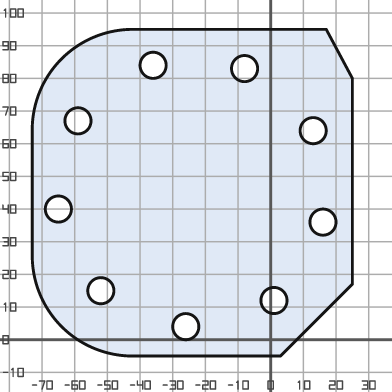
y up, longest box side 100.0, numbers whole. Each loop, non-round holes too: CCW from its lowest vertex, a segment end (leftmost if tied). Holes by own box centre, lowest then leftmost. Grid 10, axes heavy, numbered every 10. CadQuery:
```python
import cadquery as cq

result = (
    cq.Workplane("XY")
    .moveTo(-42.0, -5.0)
    .lineTo(3.0, -5.0)
    .lineTo(25.0, 17.0)
    .lineTo(25.0, 80.0)
    .lineTo(17.0, 95.0)
    .lineTo(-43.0, 95.0)
    .threePointArc((-64.0, 86.0), (-73.0, 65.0))
    .lineTo(-73.0, 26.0)
    .threePointArc((-64.0, 4.0), (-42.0, -5.0))
    .close()
    .moveTo(-26.0, 4.0)
    .circle(4.0)
    .moveTo(1.0, 12.0)
    .circle(4.0)
    .moveTo(-52.0, 15.0)
    .circle(4.0)
    .moveTo(16.0, 36.0)
    .circle(4.0)
    .moveTo(-65.0, 40.0)
    .circle(4.0)
    .moveTo(13.0, 64.0)
    .circle(4.0)
    .moveTo(-59.0, 67.0)
    .circle(4.0)
    .moveTo(-8.0, 83.0)
    .circle(4.0)
    .moveTo(-36.0, 84.0)
    .circle(4.0)
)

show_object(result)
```